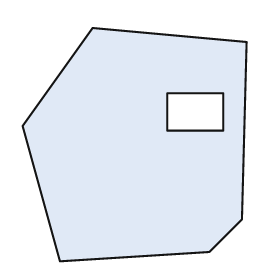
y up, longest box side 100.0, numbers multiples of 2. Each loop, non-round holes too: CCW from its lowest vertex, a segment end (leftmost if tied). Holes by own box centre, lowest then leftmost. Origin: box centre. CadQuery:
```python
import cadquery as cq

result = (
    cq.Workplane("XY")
    .moveTo(-32.0, -50.0)
    .lineTo(32.0, -46.0)
    .lineTo(46.0, -32.0)
    .lineTo(48.0, 44.0)
    .lineTo(-18.0, 50.0)
    .lineTo(-48.0, 8.0)
    .close()
    .moveTo(14.0, 6.0)
    .lineTo(38.0, 6.0)
    .lineTo(38.0, 22.0)
    .lineTo(14.0, 22.0)
    .close()
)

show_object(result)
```